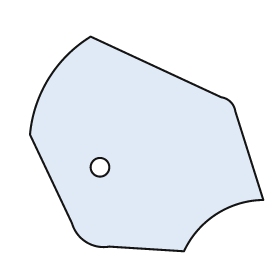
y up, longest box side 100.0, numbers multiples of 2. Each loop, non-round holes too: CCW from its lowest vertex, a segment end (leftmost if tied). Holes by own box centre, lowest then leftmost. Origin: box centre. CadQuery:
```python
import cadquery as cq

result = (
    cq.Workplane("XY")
    .moveTo(16.0, -46.0)
    .threePointArc((30.0, -30.0), (50.0, -24.0))
    .lineTo(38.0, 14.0)
    .threePointArc((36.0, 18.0), (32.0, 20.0))
    .lineTo(-24.0, 46.0)
    .threePointArc((-42.0, 28.0), (-50.0, 4.0))
    .lineTo(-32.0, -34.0)
    .threePointArc((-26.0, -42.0), (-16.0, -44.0))
    .close()
    .moveTo(-20.0, -10.0)
    .circle(4.0)
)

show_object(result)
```